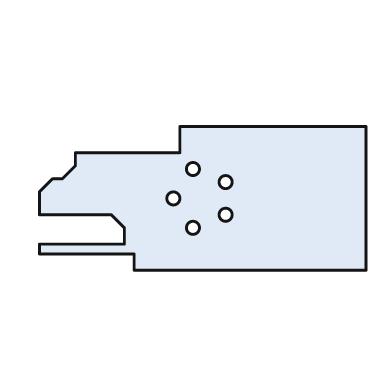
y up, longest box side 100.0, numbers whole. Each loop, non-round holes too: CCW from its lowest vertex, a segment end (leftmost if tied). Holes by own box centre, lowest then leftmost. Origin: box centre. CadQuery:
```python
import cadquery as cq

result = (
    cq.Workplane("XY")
    .moveTo(-21.0, -22.0)
    .lineTo(50.0, -22.0)
    .lineTo(50.0, 22.0)
    .lineTo(-7.0, 22.0)
    .lineTo(-7.0, 14.0)
    .lineTo(-39.0, 14.0)
    .lineTo(-39.0, 10.0)
    .lineTo(-43.0, 6.0)
    .lineTo(-46.0, 6.0)
    .lineTo(-50.0, 2.0)
    .lineTo(-50.0, -5.0)
    .lineTo(-28.0, -5.0)
    .lineTo(-24.0, -9.0)
    .lineTo(-24.0, -14.0)
    .lineTo(-50.0, -14.0)
    .lineTo(-50.0, -17.0)
    .lineTo(-21.0, -17.0)
    .close()
    .moveTo(-3.0, -9.0)
    .circle(2.0)
    .moveTo(7.0, -5.0)
    .circle(2.0)
    .moveTo(-9.0, 0.0)
    .circle(2.0)
    .moveTo(7.0, 5.0)
    .circle(2.0)
    .moveTo(-3.0, 9.0)
    .circle(2.0)
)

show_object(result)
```